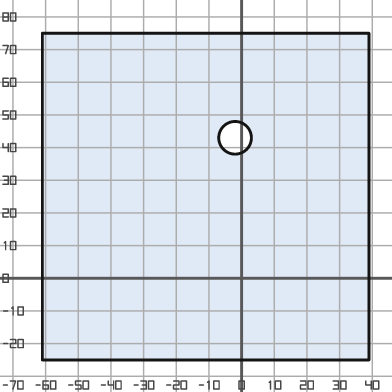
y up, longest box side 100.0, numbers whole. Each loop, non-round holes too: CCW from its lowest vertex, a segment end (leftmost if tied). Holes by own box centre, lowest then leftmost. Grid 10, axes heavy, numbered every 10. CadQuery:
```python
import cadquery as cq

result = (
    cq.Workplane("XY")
    .moveTo(-61.0, -25.0)
    .lineTo(39.0, -25.0)
    .lineTo(39.0, 75.0)
    .lineTo(-61.0, 75.0)
    .close()
    .moveTo(-2.0, 43.0)
    .circle(5.0)
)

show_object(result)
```